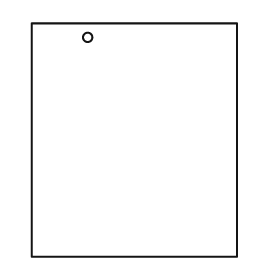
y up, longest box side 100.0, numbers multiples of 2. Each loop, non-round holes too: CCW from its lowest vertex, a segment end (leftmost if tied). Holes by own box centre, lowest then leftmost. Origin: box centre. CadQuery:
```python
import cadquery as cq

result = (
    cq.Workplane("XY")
    .moveTo(-44.0, -50.0)
    .lineTo(44.0, -50.0)
    .lineTo(44.0, 50.0)
    .lineTo(-44.0, 50.0)
    .close()
    .moveTo(-20.0, 44.0)
    .circle(2.0)
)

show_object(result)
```